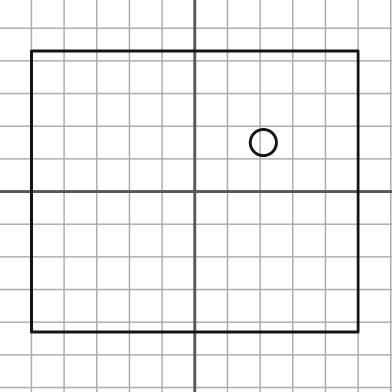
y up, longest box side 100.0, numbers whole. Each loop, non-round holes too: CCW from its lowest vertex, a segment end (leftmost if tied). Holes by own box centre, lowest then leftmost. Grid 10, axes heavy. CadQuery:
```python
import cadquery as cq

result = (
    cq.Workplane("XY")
    .moveTo(-50.0, -43.0)
    .lineTo(50.0, -43.0)
    .lineTo(50.0, 43.0)
    .lineTo(-50.0, 43.0)
    .close()
    .moveTo(21.0, 15.0)
    .circle(4.0)
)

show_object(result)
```